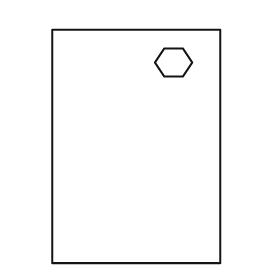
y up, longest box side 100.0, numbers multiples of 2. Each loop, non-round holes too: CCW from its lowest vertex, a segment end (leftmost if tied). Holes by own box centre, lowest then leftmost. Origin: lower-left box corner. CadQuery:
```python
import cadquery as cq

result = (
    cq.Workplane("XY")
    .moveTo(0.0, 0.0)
    .lineTo(72.0, 0.0)
    .lineTo(72.0, 100.0)
    .lineTo(0.0, 100.0)
    .close()
    .moveTo(48.0, 80.0)
    .lineTo(56.0, 80.0)
    .lineTo(60.0, 86.0)
    .lineTo(56.0, 92.0)
    .lineTo(48.0, 92.0)
    .lineTo(44.0, 86.0)
    .close()
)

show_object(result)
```